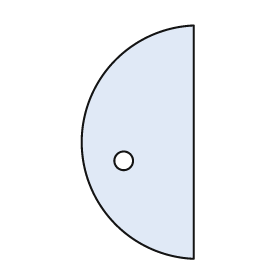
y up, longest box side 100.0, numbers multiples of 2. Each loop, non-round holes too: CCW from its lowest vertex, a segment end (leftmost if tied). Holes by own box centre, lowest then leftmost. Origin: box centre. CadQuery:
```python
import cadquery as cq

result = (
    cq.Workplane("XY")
    .moveTo(24.0, -50.0)
    .lineTo(24.0, 50.0)
    .threePointArc((-24.0, 0.0), (24.0, -50.0))
    .close()
    .moveTo(-6.0, -8.0)
    .circle(4.0)
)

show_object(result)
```